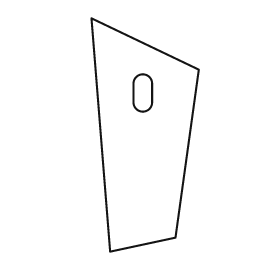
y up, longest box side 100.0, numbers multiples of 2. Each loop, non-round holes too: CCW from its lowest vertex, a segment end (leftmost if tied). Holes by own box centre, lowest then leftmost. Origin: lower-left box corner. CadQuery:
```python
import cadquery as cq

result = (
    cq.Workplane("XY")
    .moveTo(8.0, 0.0)
    .lineTo(36.0, 6.0)
    .lineTo(46.0, 78.0)
    .lineTo(0.0, 100.0)
    .close()
    .moveTo(18.0, 64.0)
    .threePointArc((22.0, 60.0), (26.0, 64.0))
    .lineTo(26.0, 72.0)
    .threePointArc((22.0, 76.0), (18.0, 72.0))
    .close()
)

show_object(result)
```